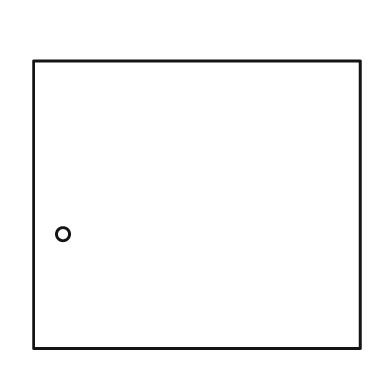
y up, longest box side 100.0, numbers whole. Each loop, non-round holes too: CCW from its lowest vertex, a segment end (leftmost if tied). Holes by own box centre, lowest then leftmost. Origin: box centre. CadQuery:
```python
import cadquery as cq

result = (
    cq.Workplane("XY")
    .moveTo(-50.0, -44.0)
    .lineTo(50.0, -44.0)
    .lineTo(50.0, 44.0)
    .lineTo(-50.0, 44.0)
    .close()
    .moveTo(-41.0, -9.0)
    .circle(2.0)
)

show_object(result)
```